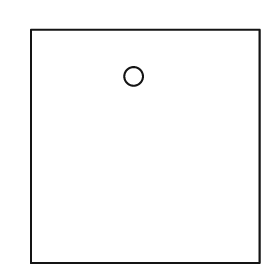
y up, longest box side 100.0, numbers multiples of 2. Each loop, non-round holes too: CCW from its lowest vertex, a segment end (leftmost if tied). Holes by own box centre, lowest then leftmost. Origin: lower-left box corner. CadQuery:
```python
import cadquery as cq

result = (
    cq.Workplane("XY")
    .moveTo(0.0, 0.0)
    .lineTo(98.0, 0.0)
    .lineTo(98.0, 100.0)
    .lineTo(0.0, 100.0)
    .close()
    .moveTo(44.0, 80.0)
    .circle(4.0)
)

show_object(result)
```